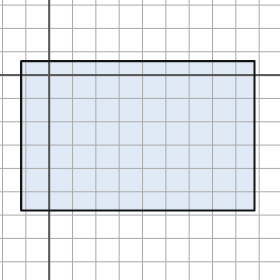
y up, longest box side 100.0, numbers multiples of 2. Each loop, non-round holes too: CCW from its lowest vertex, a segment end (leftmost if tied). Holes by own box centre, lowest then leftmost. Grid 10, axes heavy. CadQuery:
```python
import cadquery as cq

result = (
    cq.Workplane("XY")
    .moveTo(-12.0, -58.0)
    .lineTo(88.0, -58.0)
    .lineTo(88.0, 6.0)
    .lineTo(-12.0, 6.0)
    .close()
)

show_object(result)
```